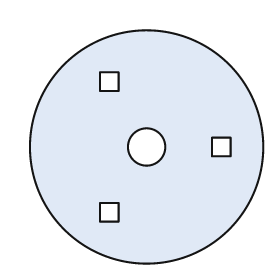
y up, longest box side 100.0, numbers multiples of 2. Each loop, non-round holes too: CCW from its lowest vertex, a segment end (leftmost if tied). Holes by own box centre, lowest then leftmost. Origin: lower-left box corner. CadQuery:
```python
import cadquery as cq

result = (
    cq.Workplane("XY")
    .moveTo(50.0, 50.0)
    .circle(50.0)
    .moveTo(30.0, 18.0)
    .lineTo(38.0, 18.0)
    .lineTo(38.0, 26.0)
    .lineTo(30.0, 26.0)
    .close()
    .moveTo(50.0, 50.0)
    .circle(8.0)
    .moveTo(78.0, 46.0)
    .lineTo(86.0, 46.0)
    .lineTo(86.0, 54.0)
    .lineTo(78.0, 54.0)
    .close()
    .moveTo(30.0, 74.0)
    .lineTo(38.0, 74.0)
    .lineTo(38.0, 82.0)
    .lineTo(30.0, 82.0)
    .close()
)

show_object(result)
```